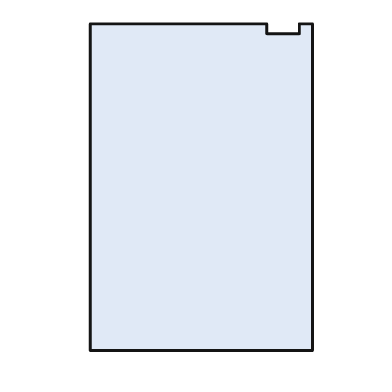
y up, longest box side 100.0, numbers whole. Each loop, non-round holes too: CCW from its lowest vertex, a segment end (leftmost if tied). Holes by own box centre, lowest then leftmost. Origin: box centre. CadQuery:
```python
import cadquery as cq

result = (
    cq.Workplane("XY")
    .moveTo(-34.0, -50.0)
    .lineTo(34.0, -50.0)
    .lineTo(34.0, 50.0)
    .lineTo(30.0, 50.0)
    .lineTo(30.0, 47.0)
    .lineTo(20.0, 47.0)
    .lineTo(20.0, 50.0)
    .lineTo(-34.0, 50.0)
    .close()
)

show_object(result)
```